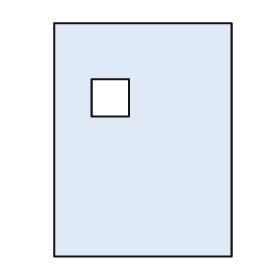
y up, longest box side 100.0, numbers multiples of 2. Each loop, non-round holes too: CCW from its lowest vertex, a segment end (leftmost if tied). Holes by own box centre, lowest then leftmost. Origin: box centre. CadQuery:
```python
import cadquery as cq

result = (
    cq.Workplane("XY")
    .moveTo(-38.0, -50.0)
    .lineTo(38.0, -50.0)
    .lineTo(38.0, 50.0)
    .lineTo(-38.0, 50.0)
    .close()
    .moveTo(-22.0, 10.0)
    .lineTo(-6.0, 10.0)
    .lineTo(-6.0, 26.0)
    .lineTo(-22.0, 26.0)
    .close()
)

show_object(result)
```